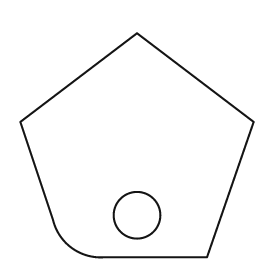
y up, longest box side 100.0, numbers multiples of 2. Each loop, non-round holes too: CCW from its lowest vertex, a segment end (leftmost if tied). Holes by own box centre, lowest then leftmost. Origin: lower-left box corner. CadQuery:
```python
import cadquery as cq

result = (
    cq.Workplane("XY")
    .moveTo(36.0, 0.0)
    .lineTo(80.0, 0.0)
    .lineTo(100.0, 58.0)
    .lineTo(50.0, 96.0)
    .lineTo(0.0, 58.0)
    .lineTo(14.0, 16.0)
    .threePointArc((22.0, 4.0), (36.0, 0.0))
    .close()
    .moveTo(50.0, 18.0)
    .circle(10.0)
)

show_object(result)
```